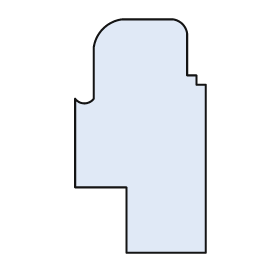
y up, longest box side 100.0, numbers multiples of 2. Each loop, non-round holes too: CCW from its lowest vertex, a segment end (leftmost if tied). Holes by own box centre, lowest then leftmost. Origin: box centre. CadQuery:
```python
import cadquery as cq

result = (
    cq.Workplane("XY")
    .moveTo(-6.0, -50.0)
    .lineTo(28.0, -50.0)
    .lineTo(28.0, 22.0)
    .lineTo(24.0, 22.0)
    .lineTo(24.0, 26.0)
    .lineTo(20.0, 26.0)
    .lineTo(20.0, 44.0)
    .threePointArc((18.0, 48.0), (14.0, 50.0))
    .lineTo(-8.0, 50.0)
    .threePointArc((-16.0, 46.0), (-20.0, 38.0))
    .lineTo(-20.0, 16.0)
    .threePointArc((-24.0, 14.0), (-28.0, 16.0))
    .lineTo(-28.0, -22.0)
    .lineTo(-6.0, -22.0)
    .close()
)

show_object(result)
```